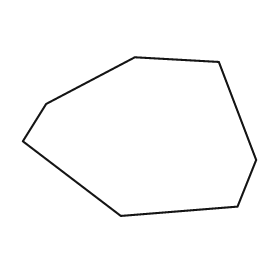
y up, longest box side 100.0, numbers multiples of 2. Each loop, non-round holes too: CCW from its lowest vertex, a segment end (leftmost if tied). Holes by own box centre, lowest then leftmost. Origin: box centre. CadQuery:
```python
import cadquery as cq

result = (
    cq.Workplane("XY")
    .moveTo(-8.0, -34.0)
    .lineTo(42.0, -30.0)
    .lineTo(50.0, -10.0)
    .lineTo(34.0, 32.0)
    .lineTo(-2.0, 34.0)
    .lineTo(-40.0, 14.0)
    .lineTo(-50.0, -2.0)
    .close()
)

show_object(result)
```